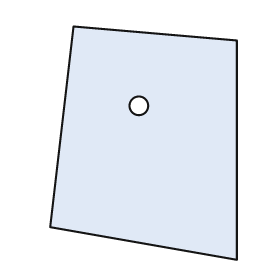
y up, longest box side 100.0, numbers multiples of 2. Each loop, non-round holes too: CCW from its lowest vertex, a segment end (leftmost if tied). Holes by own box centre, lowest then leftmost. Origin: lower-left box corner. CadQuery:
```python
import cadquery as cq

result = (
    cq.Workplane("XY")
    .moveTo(80.0, 0.0)
    .lineTo(80.0, 94.0)
    .lineTo(10.0, 100.0)
    .lineTo(0.0, 14.0)
    .close()
    .moveTo(38.0, 66.0)
    .circle(4.0)
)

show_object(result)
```